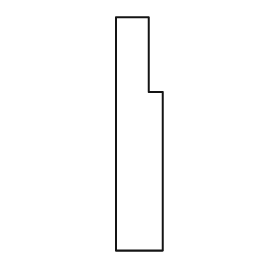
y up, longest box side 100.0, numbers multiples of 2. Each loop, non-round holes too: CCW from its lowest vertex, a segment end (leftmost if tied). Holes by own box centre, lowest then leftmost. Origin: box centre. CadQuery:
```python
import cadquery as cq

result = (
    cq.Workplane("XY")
    .moveTo(-10.0, -50.0)
    .lineTo(10.0, -50.0)
    .lineTo(10.0, 18.0)
    .lineTo(4.0, 18.0)
    .lineTo(4.0, 50.0)
    .lineTo(-10.0, 50.0)
    .close()
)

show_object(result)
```